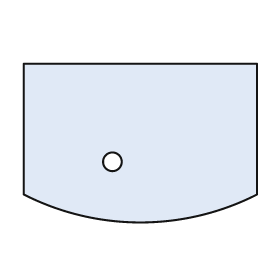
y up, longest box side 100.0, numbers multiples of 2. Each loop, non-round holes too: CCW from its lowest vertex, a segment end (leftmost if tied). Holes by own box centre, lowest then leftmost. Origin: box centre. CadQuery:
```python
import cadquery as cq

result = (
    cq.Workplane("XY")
    .moveTo(-50.0, -22.0)
    .threePointArc((0.0, -34.0), (50.0, -22.0))
    .lineTo(50.0, 34.0)
    .lineTo(-50.0, 34.0)
    .close()
    .moveTo(-12.0, -8.0)
    .circle(4.0)
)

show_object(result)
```